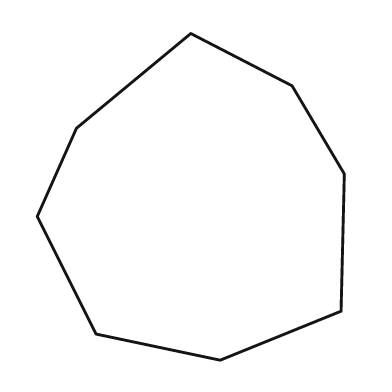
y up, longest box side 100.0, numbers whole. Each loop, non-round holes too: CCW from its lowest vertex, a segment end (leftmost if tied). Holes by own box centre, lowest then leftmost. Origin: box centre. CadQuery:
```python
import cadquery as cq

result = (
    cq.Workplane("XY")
    .moveTo(9.0, -50.0)
    .lineTo(46.0, -35.0)
    .lineTo(47.0, 7.0)
    .lineTo(31.0, 34.0)
    .lineTo(0.0, 50.0)
    .lineTo(-35.0, 21.0)
    .lineTo(-47.0, -6.0)
    .lineTo(-29.0, -42.0)
    .close()
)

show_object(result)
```